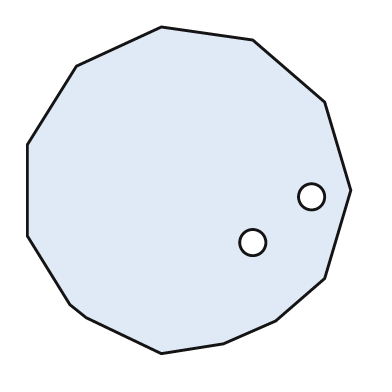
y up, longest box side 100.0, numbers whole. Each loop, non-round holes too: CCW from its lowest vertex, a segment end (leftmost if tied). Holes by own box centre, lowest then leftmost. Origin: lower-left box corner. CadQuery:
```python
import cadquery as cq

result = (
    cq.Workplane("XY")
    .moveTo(41.0, 0.0)
    .lineTo(60.0, 3.0)
    .lineTo(76.0, 10.0)
    .lineTo(91.0, 23.0)
    .lineTo(99.0, 50.0)
    .lineTo(91.0, 77.0)
    .lineTo(69.0, 96.0)
    .lineTo(41.0, 100.0)
    .lineTo(15.0, 88.0)
    .lineTo(0.0, 64.0)
    .lineTo(0.0, 36.0)
    .lineTo(13.0, 15.0)
    .lineTo(18.0, 11.0)
    .close()
    .moveTo(69.0, 34.0)
    .circle(4.0)
    .moveTo(87.0, 48.0)
    .circle(4.0)
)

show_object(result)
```